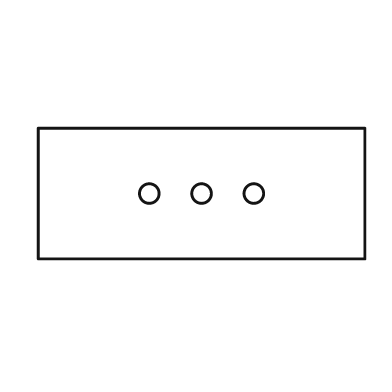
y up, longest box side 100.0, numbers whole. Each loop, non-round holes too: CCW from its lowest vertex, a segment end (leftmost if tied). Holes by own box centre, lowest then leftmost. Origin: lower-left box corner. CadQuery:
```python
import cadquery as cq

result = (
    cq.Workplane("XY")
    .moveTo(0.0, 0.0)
    .lineTo(100.0, 0.0)
    .lineTo(100.0, 40.0)
    .lineTo(0.0, 40.0)
    .close()
    .moveTo(34.0, 20.0)
    .circle(3.0)
    .moveTo(50.0, 20.0)
    .circle(3.0)
    .moveTo(66.0, 20.0)
    .circle(3.0)
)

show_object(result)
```